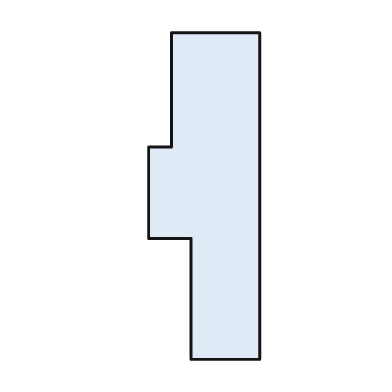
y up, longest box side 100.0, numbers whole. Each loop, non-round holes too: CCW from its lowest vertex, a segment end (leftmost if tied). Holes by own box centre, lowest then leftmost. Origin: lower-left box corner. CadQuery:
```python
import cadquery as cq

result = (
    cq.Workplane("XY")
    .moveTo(13.0, 0.0)
    .lineTo(34.0, 0.0)
    .lineTo(34.0, 100.0)
    .lineTo(7.0, 100.0)
    .lineTo(7.0, 65.0)
    .lineTo(0.0, 65.0)
    .lineTo(0.0, 37.0)
    .lineTo(13.0, 37.0)
    .close()
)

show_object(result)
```